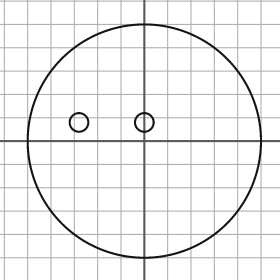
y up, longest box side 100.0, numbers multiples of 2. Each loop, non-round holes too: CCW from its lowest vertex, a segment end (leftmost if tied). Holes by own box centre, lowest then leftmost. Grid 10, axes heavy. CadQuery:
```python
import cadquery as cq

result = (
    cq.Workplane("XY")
    .moveTo(0.0, 0.0)
    .circle(50.0)
    .moveTo(-28.0, 8.0)
    .circle(4.0)
    .moveTo(0.0, 8.0)
    .circle(4.0)
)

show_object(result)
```